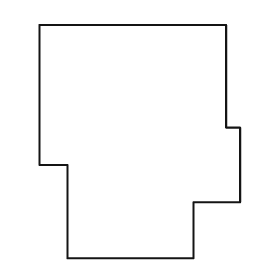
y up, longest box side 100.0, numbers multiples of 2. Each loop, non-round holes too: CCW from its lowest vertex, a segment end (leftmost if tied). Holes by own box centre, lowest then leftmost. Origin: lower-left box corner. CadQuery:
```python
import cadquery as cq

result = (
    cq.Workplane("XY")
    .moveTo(12.0, 0.0)
    .lineTo(66.0, 0.0)
    .lineTo(66.0, 24.0)
    .lineTo(86.0, 24.0)
    .lineTo(86.0, 56.0)
    .lineTo(80.0, 56.0)
    .lineTo(80.0, 100.0)
    .lineTo(0.0, 100.0)
    .lineTo(0.0, 40.0)
    .lineTo(12.0, 40.0)
    .close()
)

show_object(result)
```